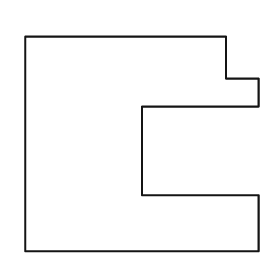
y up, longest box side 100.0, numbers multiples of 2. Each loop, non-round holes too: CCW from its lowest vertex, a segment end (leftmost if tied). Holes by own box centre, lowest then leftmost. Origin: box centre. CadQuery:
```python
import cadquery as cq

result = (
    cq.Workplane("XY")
    .moveTo(-50.0, -46.0)
    .lineTo(50.0, -46.0)
    .lineTo(50.0, -22.0)
    .lineTo(0.0, -22.0)
    .lineTo(0.0, 16.0)
    .lineTo(50.0, 16.0)
    .lineTo(50.0, 28.0)
    .lineTo(36.0, 28.0)
    .lineTo(36.0, 46.0)
    .lineTo(-50.0, 46.0)
    .close()
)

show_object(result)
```